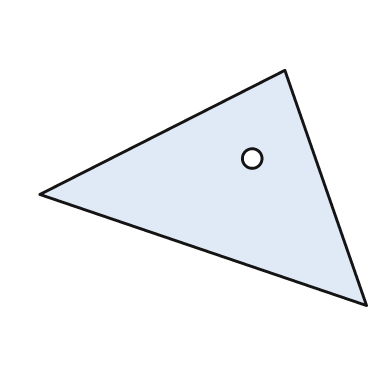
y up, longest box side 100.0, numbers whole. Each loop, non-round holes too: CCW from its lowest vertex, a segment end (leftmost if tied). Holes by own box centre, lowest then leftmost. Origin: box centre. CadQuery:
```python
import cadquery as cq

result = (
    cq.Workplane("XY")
    .moveTo(50.0, -36.0)
    .lineTo(25.0, 36.0)
    .lineTo(-50.0, -2.0)
    .close()
    .moveTo(15.0, 9.0)
    .circle(3.0)
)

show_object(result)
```